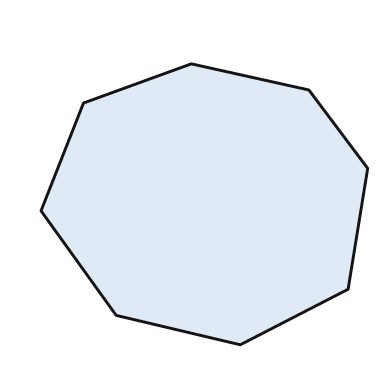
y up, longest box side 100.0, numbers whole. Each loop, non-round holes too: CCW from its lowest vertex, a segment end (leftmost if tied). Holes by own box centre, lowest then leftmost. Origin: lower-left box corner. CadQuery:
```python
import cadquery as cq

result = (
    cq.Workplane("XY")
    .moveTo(61.0, 0.0)
    .lineTo(94.0, 17.0)
    .lineTo(100.0, 54.0)
    .lineTo(82.0, 78.0)
    .lineTo(46.0, 86.0)
    .lineTo(13.0, 74.0)
    .lineTo(0.0, 41.0)
    .lineTo(23.0, 9.0)
    .close()
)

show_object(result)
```